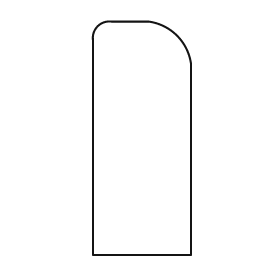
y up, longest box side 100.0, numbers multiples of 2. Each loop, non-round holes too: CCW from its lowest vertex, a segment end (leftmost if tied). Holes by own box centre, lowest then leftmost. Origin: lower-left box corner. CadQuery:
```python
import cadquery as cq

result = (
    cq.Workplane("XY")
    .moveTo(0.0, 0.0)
    .lineTo(42.0, 0.0)
    .lineTo(42.0, 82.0)
    .threePointArc((36.0, 94.0), (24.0, 100.0))
    .lineTo(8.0, 100.0)
    .threePointArc((2.0, 98.0), (0.0, 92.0))
    .close()
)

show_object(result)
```